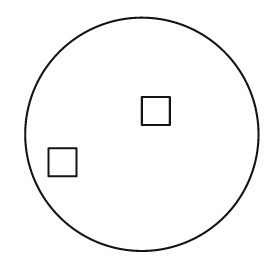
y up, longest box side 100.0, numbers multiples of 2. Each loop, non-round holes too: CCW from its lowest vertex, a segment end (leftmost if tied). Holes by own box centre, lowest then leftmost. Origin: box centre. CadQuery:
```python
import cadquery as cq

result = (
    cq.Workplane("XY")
    .moveTo(0.0, 0.0)
    .circle(50.0)
    .moveTo(-40.0, -18.0)
    .lineTo(-28.0, -18.0)
    .lineTo(-28.0, -6.0)
    .lineTo(-40.0, -6.0)
    .close()
    .moveTo(0.0, 4.0)
    .lineTo(12.0, 4.0)
    .lineTo(12.0, 16.0)
    .lineTo(0.0, 16.0)
    .close()
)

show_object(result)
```